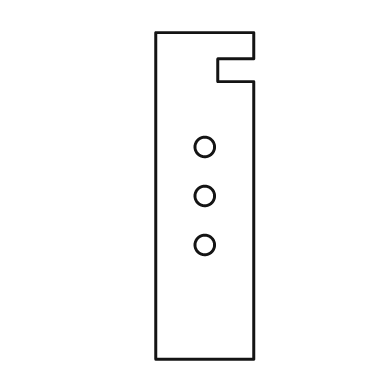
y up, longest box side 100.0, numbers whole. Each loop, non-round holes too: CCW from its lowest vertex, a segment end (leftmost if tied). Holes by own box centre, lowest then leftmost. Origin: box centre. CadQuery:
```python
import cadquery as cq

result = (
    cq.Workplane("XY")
    .moveTo(-15.0, -50.0)
    .lineTo(15.0, -50.0)
    .lineTo(15.0, 35.0)
    .lineTo(4.0, 35.0)
    .lineTo(4.0, 42.0)
    .lineTo(15.0, 42.0)
    .lineTo(15.0, 50.0)
    .lineTo(-15.0, 50.0)
    .close()
    .moveTo(0.0, -15.0)
    .circle(3.0)
    .moveTo(0.0, 0.0)
    .circle(3.0)
    .moveTo(0.0, 15.0)
    .circle(3.0)
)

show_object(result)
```